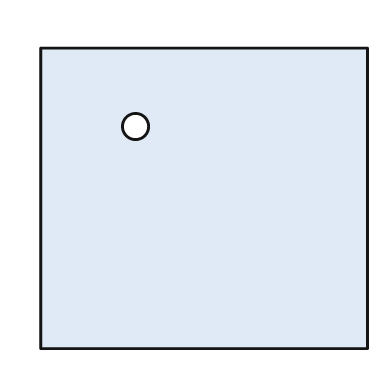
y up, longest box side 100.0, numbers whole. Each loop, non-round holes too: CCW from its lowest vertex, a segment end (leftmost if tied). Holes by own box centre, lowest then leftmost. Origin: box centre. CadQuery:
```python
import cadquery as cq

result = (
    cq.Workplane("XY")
    .moveTo(-50.0, -46.0)
    .lineTo(50.0, -46.0)
    .lineTo(50.0, 46.0)
    .lineTo(-50.0, 46.0)
    .close()
    .moveTo(-21.0, 22.0)
    .circle(4.0)
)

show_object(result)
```